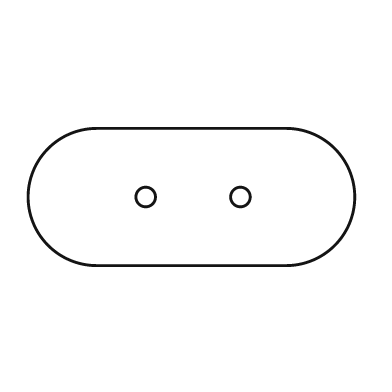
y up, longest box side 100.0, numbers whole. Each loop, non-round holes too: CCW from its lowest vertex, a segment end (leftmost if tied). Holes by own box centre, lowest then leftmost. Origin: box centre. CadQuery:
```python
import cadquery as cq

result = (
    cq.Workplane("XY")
    .moveTo(-29.0, -21.0)
    .lineTo(29.0, -21.0)
    .threePointArc((50.0, 0.0), (29.0, 21.0))
    .lineTo(-29.0, 21.0)
    .threePointArc((-50.0, 0.0), (-29.0, -21.0))
    .close()
    .moveTo(-14.0, 0.0)
    .circle(3.0)
    .moveTo(15.0, 0.0)
    .circle(3.0)
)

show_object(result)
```